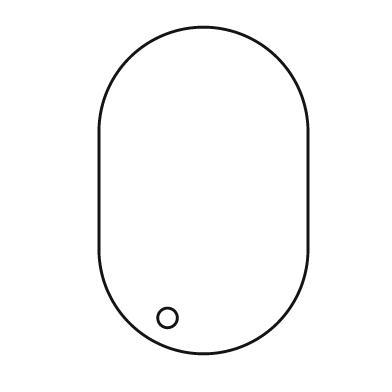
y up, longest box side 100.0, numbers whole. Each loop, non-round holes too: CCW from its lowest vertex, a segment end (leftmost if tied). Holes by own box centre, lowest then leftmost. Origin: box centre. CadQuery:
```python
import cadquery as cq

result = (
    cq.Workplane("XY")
    .moveTo(-32.0, -18.0)
    .threePointArc((0.0, -50.0), (32.0, -18.0))
    .lineTo(32.0, 18.0)
    .threePointArc((0.0, 50.0), (-32.0, 18.0))
    .close()
    .moveTo(-11.0, -39.0)
    .circle(3.0)
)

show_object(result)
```